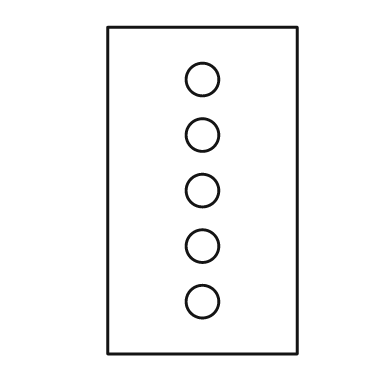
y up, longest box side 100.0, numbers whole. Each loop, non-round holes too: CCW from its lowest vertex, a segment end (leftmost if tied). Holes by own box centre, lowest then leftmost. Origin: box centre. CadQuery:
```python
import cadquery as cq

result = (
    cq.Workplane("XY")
    .moveTo(-29.0, -50.0)
    .lineTo(29.0, -50.0)
    .lineTo(29.0, 50.0)
    .lineTo(-29.0, 50.0)
    .close()
    .moveTo(0.0, -34.0)
    .circle(5.0)
    .moveTo(0.0, -17.0)
    .circle(5.0)
    .moveTo(0.0, 0.0)
    .circle(5.0)
    .moveTo(0.0, 17.0)
    .circle(5.0)
    .moveTo(0.0, 34.0)
    .circle(5.0)
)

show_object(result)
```